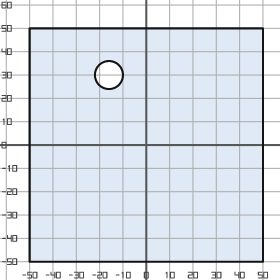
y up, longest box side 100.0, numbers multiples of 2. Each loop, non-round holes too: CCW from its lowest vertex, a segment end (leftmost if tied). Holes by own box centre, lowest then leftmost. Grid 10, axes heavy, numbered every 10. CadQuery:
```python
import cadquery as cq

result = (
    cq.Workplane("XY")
    .moveTo(-50.0, -50.0)
    .lineTo(50.0, -50.0)
    .lineTo(50.0, 50.0)
    .lineTo(-50.0, 50.0)
    .close()
    .moveTo(-16.0, 30.0)
    .circle(6.0)
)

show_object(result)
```